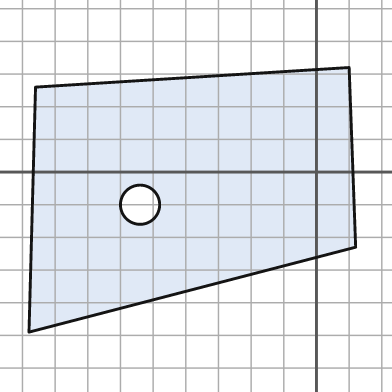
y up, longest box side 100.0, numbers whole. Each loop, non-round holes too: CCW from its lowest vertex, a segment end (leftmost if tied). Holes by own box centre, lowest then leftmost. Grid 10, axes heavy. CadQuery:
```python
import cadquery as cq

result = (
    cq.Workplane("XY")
    .moveTo(-88.0, -49.0)
    .lineTo(12.0, -23.0)
    .lineTo(10.0, 32.0)
    .lineTo(-86.0, 26.0)
    .close()
    .moveTo(-54.0, -10.0)
    .circle(6.0)
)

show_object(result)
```